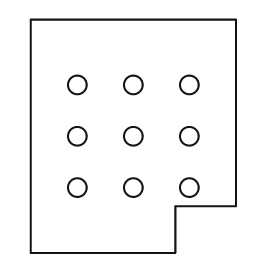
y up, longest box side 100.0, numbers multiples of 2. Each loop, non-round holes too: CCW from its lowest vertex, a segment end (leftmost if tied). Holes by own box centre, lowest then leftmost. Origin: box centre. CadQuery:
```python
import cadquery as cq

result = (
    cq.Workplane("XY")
    .moveTo(-44.0, -50.0)
    .lineTo(18.0, -50.0)
    .lineTo(18.0, -30.0)
    .lineTo(44.0, -30.0)
    .lineTo(44.0, 50.0)
    .lineTo(-44.0, 50.0)
    .close()
    .moveTo(-24.0, -22.0)
    .circle(4.0)
    .moveTo(0.0, -22.0)
    .circle(4.0)
    .moveTo(24.0, -22.0)
    .circle(4.0)
    .moveTo(-24.0, 0.0)
    .circle(4.0)
    .moveTo(0.0, 0.0)
    .circle(4.0)
    .moveTo(24.0, 0.0)
    .circle(4.0)
    .moveTo(-24.0, 22.0)
    .circle(4.0)
    .moveTo(0.0, 22.0)
    .circle(4.0)
    .moveTo(24.0, 22.0)
    .circle(4.0)
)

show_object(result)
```